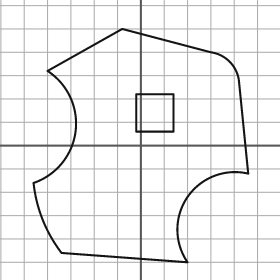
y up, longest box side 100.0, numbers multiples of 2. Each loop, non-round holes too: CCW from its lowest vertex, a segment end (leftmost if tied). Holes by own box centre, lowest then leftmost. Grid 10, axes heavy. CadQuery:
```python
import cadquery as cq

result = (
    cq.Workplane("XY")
    .moveTo(20.0, -50.0)
    .threePointArc((20.0, -22.0), (46.0, -12.0))
    .lineTo(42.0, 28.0)
    .threePointArc((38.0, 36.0), (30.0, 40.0))
    .lineTo(-8.0, 50.0)
    .lineTo(-40.0, 32.0)
    .threePointArc((-28.0, 6.0), (-46.0, -16.0))
    .threePointArc((-42.0, -32.0), (-34.0, -46.0))
    .close()
    .moveTo(-2.0, 6.0)
    .lineTo(14.0, 6.0)
    .lineTo(14.0, 22.0)
    .lineTo(-2.0, 22.0)
    .close()
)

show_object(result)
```